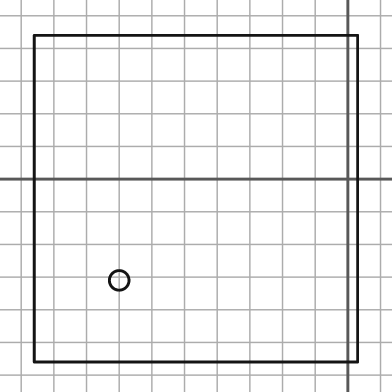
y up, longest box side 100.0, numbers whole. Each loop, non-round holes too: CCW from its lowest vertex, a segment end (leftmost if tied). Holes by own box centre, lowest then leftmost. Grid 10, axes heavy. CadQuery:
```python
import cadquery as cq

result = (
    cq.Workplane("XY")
    .moveTo(-96.0, -56.0)
    .lineTo(3.0, -56.0)
    .lineTo(3.0, 44.0)
    .lineTo(-96.0, 44.0)
    .close()
    .moveTo(-70.0, -31.0)
    .circle(3.0)
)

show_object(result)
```